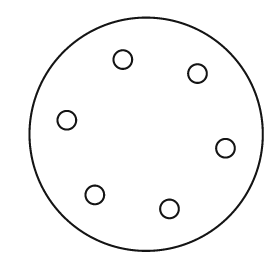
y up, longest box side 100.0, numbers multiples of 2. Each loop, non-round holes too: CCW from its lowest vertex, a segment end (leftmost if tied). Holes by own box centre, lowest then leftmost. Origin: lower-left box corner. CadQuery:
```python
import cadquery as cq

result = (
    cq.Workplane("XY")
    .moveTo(50.0, 50.0)
    .circle(50.0)
    .moveTo(60.0, 18.0)
    .circle(4.0)
    .moveTo(28.0, 24.0)
    .circle(4.0)
    .moveTo(84.0, 44.0)
    .circle(4.0)
    .moveTo(16.0, 56.0)
    .circle(4.0)
    .moveTo(72.0, 76.0)
    .circle(4.0)
    .moveTo(40.0, 82.0)
    .circle(4.0)
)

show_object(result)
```